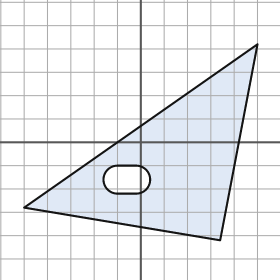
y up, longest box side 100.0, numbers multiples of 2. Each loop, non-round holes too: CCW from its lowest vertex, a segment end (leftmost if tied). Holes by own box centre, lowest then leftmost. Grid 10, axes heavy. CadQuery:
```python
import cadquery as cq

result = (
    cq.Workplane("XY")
    .moveTo(34.0, -42.0)
    .lineTo(50.0, 42.0)
    .lineTo(-50.0, -28.0)
    .close()
    .moveTo(-10.0, -22.0)
    .lineTo(-2.0, -22.0)
    .threePointArc((4.0, -16.0), (-2.0, -10.0))
    .lineTo(-10.0, -10.0)
    .threePointArc((-16.0, -16.0), (-10.0, -22.0))
    .close()
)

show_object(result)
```